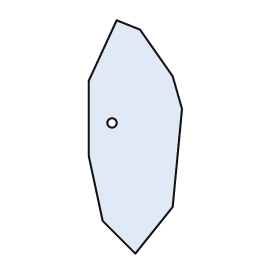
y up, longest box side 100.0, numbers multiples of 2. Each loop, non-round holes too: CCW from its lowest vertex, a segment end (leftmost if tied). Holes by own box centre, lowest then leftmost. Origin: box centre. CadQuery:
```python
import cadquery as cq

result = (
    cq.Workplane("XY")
    .moveTo(0.0, -50.0)
    .lineTo(16.0, -30.0)
    .lineTo(20.0, 12.0)
    .lineTo(16.0, 26.0)
    .lineTo(2.0, 46.0)
    .lineTo(-8.0, 50.0)
    .lineTo(-20.0, 24.0)
    .lineTo(-20.0, -8.0)
    .lineTo(-14.0, -36.0)
    .close()
    .moveTo(-10.0, 6.0)
    .circle(2.0)
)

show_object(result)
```